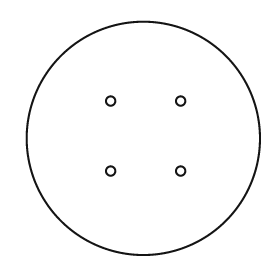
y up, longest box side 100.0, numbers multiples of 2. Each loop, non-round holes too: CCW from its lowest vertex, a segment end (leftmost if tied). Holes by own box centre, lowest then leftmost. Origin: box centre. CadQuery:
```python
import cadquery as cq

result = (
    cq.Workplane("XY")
    .moveTo(0.0, 0.0)
    .circle(50.0)
    .moveTo(-14.0, -14.0)
    .circle(2.0)
    .moveTo(16.0, -14.0)
    .circle(2.0)
    .moveTo(-14.0, 16.0)
    .circle(2.0)
    .moveTo(16.0, 16.0)
    .circle(2.0)
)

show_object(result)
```